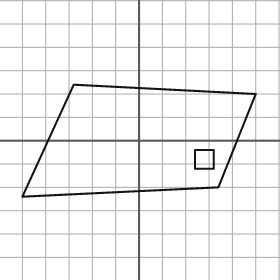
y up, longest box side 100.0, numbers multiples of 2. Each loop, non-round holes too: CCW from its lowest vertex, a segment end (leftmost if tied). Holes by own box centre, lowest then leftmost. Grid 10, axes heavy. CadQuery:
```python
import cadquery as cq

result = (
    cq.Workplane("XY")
    .moveTo(-50.0, -24.0)
    .lineTo(34.0, -20.0)
    .lineTo(50.0, 20.0)
    .lineTo(-28.0, 24.0)
    .close()
    .moveTo(24.0, -12.0)
    .lineTo(32.0, -12.0)
    .lineTo(32.0, -4.0)
    .lineTo(24.0, -4.0)
    .close()
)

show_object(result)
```